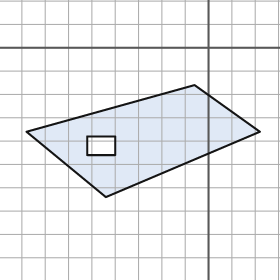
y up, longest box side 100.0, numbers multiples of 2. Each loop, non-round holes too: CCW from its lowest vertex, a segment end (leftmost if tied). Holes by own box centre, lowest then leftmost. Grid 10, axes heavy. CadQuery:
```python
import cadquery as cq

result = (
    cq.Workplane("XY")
    .moveTo(-44.0, -64.0)
    .lineTo(22.0, -36.0)
    .lineTo(-6.0, -16.0)
    .lineTo(-78.0, -36.0)
    .close()
    .moveTo(-52.0, -46.0)
    .lineTo(-40.0, -46.0)
    .lineTo(-40.0, -38.0)
    .lineTo(-52.0, -38.0)
    .close()
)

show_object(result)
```